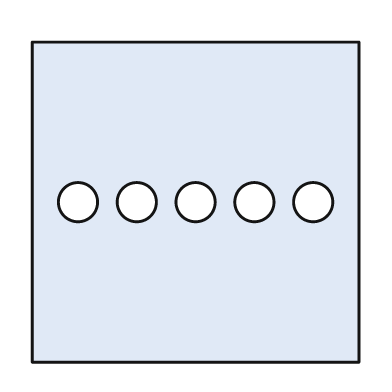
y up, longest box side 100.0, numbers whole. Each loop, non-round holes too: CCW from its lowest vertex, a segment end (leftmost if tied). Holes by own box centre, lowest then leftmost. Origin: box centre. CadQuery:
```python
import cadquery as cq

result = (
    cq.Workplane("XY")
    .moveTo(-50.0, -49.0)
    .lineTo(50.0, -49.0)
    .lineTo(50.0, 49.0)
    .lineTo(-50.0, 49.0)
    .close()
    .moveTo(-36.0, 0.0)
    .circle(6.0)
    .moveTo(-18.0, 0.0)
    .circle(6.0)
    .moveTo(0.0, 0.0)
    .circle(6.0)
    .moveTo(18.0, 0.0)
    .circle(6.0)
    .moveTo(36.0, 0.0)
    .circle(6.0)
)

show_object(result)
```